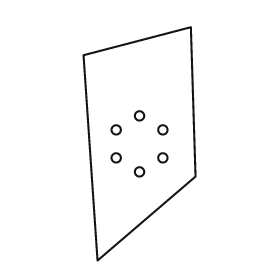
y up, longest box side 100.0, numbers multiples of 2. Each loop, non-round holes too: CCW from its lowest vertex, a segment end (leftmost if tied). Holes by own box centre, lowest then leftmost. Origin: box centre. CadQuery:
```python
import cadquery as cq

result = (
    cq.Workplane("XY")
    .moveTo(-18.0, -50.0)
    .lineTo(24.0, -14.0)
    .lineTo(22.0, 50.0)
    .lineTo(-24.0, 38.0)
    .close()
    .moveTo(0.0, -12.0)
    .circle(2.0)
    .moveTo(-10.0, -6.0)
    .circle(2.0)
    .moveTo(10.0, -6.0)
    .circle(2.0)
    .moveTo(-10.0, 6.0)
    .circle(2.0)
    .moveTo(10.0, 6.0)
    .circle(2.0)
    .moveTo(0.0, 12.0)
    .circle(2.0)
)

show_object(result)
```